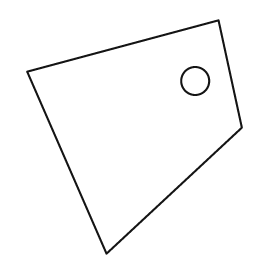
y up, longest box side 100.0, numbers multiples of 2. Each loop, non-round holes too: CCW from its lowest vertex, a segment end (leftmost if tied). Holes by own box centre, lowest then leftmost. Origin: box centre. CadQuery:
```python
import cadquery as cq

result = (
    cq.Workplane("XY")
    .moveTo(-12.0, -50.0)
    .lineTo(46.0, 4.0)
    .lineTo(36.0, 50.0)
    .lineTo(-46.0, 28.0)
    .close()
    .moveTo(26.0, 24.0)
    .circle(6.0)
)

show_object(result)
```